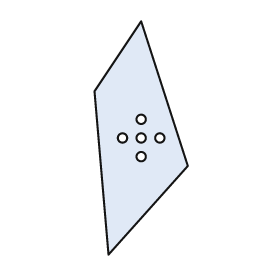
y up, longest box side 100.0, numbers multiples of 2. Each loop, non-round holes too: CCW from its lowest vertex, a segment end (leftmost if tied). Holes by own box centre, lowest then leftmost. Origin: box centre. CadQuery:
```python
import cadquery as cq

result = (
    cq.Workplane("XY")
    .moveTo(-14.0, -50.0)
    .lineTo(20.0, -12.0)
    .lineTo(0.0, 50.0)
    .lineTo(-20.0, 20.0)
    .close()
    .moveTo(0.0, -8.0)
    .circle(2.0)
    .moveTo(-8.0, 0.0)
    .circle(2.0)
    .moveTo(0.0, 0.0)
    .circle(2.0)
    .moveTo(8.0, 0.0)
    .circle(2.0)
    .moveTo(0.0, 8.0)
    .circle(2.0)
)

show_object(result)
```